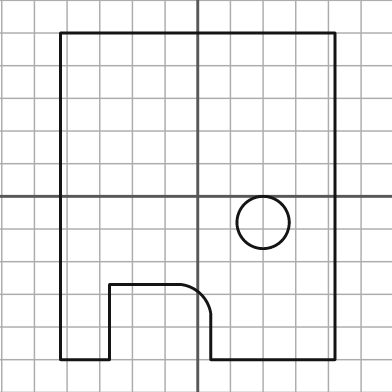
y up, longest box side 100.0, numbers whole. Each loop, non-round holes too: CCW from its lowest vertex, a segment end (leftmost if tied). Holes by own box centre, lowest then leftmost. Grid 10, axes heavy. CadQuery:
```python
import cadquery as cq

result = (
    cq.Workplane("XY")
    .moveTo(-42.0, -50.0)
    .lineTo(-27.0, -50.0)
    .lineTo(-27.0, -27.0)
    .lineTo(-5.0, -27.0)
    .threePointArc((1.0, -30.0), (4.0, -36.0))
    .lineTo(4.0, -50.0)
    .lineTo(42.0, -50.0)
    .lineTo(42.0, 50.0)
    .lineTo(-42.0, 50.0)
    .close()
    .moveTo(20.0, -8.0)
    .circle(8.0)
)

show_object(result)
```